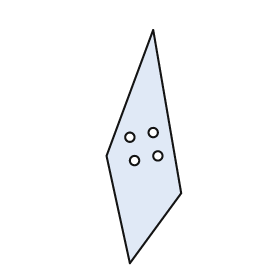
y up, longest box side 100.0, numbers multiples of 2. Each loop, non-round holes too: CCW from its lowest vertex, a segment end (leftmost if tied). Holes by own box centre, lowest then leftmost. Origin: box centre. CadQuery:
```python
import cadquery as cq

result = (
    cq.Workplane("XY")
    .moveTo(-6.0, -50.0)
    .lineTo(16.0, -20.0)
    .lineTo(4.0, 50.0)
    .lineTo(-16.0, -4.0)
    .close()
    .moveTo(-4.0, -6.0)
    .circle(2.0)
    .moveTo(6.0, -4.0)
    .circle(2.0)
    .moveTo(-6.0, 4.0)
    .circle(2.0)
    .moveTo(4.0, 6.0)
    .circle(2.0)
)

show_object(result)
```